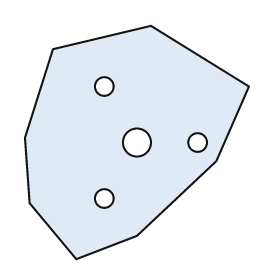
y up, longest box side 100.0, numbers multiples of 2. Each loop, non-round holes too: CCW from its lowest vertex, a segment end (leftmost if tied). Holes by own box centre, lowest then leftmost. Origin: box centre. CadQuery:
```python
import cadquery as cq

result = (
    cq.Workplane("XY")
    .moveTo(-26.0, -50.0)
    .lineTo(0.0, -40.0)
    .lineTo(34.0, -8.0)
    .lineTo(48.0, 24.0)
    .lineTo(6.0, 50.0)
    .lineTo(-36.0, 40.0)
    .lineTo(-48.0, 2.0)
    .lineTo(-46.0, -26.0)
    .close()
    .moveTo(-14.0, -24.0)
    .circle(4.0)
    .moveTo(0.0, 0.0)
    .circle(6.0)
    .moveTo(26.0, 0.0)
    .circle(4.0)
    .moveTo(-14.0, 24.0)
    .circle(4.0)
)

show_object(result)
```